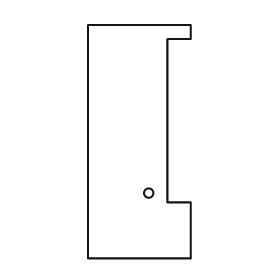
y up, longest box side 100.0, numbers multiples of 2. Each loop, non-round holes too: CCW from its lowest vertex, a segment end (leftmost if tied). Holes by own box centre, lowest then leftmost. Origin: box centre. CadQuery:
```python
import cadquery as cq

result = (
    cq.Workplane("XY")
    .moveTo(-22.0, -50.0)
    .lineTo(22.0, -50.0)
    .lineTo(22.0, -26.0)
    .lineTo(12.0, -26.0)
    .lineTo(12.0, 44.0)
    .lineTo(22.0, 44.0)
    .lineTo(22.0, 50.0)
    .lineTo(-22.0, 50.0)
    .close()
    .moveTo(4.0, -22.0)
    .circle(2.0)
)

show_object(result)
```